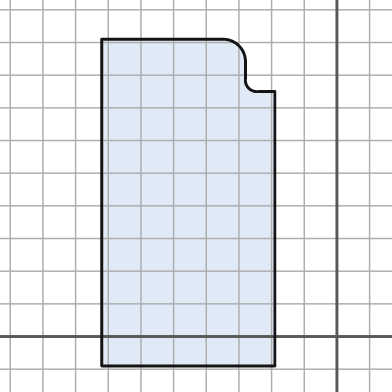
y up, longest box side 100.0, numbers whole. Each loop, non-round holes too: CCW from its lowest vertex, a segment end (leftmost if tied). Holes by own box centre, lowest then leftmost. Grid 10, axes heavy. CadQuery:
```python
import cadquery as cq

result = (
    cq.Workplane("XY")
    .moveTo(-72.0, -9.0)
    .lineTo(-19.0, -9.0)
    .lineTo(-19.0, 75.0)
    .lineTo(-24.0, 75.0)
    .threePointArc((-27.0, 76.0), (-28.0, 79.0))
    .lineTo(-28.0, 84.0)
    .threePointArc((-30.0, 89.0), (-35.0, 91.0))
    .lineTo(-72.0, 91.0)
    .close()
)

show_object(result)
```